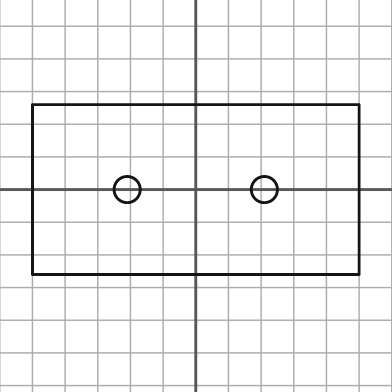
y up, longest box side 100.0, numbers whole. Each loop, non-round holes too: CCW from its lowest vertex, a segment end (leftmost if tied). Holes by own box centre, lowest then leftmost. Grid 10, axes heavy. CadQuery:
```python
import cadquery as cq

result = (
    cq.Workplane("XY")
    .moveTo(-50.0, -26.0)
    .lineTo(50.0, -26.0)
    .lineTo(50.0, 26.0)
    .lineTo(-50.0, 26.0)
    .close()
    .moveTo(-21.0, 0.0)
    .circle(4.0)
    .moveTo(21.0, 0.0)
    .circle(4.0)
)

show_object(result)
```